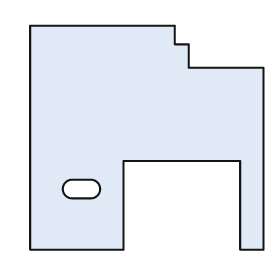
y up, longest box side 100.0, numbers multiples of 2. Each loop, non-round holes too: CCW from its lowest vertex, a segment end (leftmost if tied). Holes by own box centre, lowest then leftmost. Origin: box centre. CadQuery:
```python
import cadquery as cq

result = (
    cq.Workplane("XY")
    .moveTo(-50.0, -48.0)
    .lineTo(-10.0, -48.0)
    .lineTo(-10.0, -10.0)
    .lineTo(40.0, -10.0)
    .lineTo(40.0, -48.0)
    .lineTo(50.0, -48.0)
    .lineTo(50.0, 30.0)
    .lineTo(18.0, 30.0)
    .lineTo(18.0, 40.0)
    .lineTo(12.0, 40.0)
    .lineTo(12.0, 48.0)
    .lineTo(-50.0, 48.0)
    .close()
    .moveTo(-32.0, -26.0)
    .lineTo(-24.0, -26.0)
    .threePointArc((-20.0, -22.0), (-24.0, -18.0))
    .lineTo(-32.0, -18.0)
    .threePointArc((-36.0, -22.0), (-32.0, -26.0))
    .close()
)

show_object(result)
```